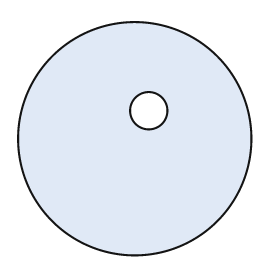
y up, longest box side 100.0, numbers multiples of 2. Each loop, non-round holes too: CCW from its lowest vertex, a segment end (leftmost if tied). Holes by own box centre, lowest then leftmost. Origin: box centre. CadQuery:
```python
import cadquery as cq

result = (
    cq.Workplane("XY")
    .moveTo(0.0, 0.0)
    .circle(50.0)
    .moveTo(6.0, 12.0)
    .circle(8.0)
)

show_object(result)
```